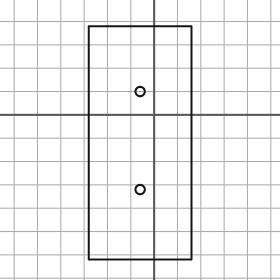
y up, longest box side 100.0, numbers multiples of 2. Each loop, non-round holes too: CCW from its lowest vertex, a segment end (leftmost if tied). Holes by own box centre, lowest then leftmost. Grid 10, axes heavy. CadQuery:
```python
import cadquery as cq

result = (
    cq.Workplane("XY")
    .moveTo(-28.0, -62.0)
    .lineTo(16.0, -62.0)
    .lineTo(16.0, 38.0)
    .lineTo(-28.0, 38.0)
    .close()
    .moveTo(-6.0, -32.0)
    .circle(2.0)
    .moveTo(-6.0, 10.0)
    .circle(2.0)
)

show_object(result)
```